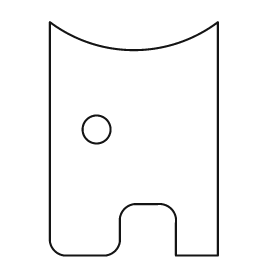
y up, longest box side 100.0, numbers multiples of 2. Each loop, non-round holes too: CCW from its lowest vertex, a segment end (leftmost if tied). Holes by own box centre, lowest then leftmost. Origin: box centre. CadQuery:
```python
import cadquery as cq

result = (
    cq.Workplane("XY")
    .moveTo(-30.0, -50.0)
    .lineTo(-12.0, -50.0)
    .threePointArc((-8.0, -48.0), (-6.0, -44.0))
    .lineTo(-6.0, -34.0)
    .threePointArc((-4.0, -30.0), (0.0, -28.0))
    .lineTo(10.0, -28.0)
    .threePointArc((16.0, -30.0), (18.0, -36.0))
    .lineTo(18.0, -50.0)
    .lineTo(36.0, -50.0)
    .lineTo(36.0, 50.0)
    .threePointArc((0.0, 38.0), (-36.0, 50.0))
    .lineTo(-36.0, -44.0)
    .threePointArc((-34.0, -48.0), (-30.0, -50.0))
    .close()
    .moveTo(-16.0, 4.0)
    .circle(6.0)
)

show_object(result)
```